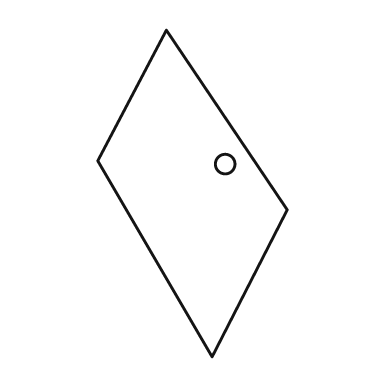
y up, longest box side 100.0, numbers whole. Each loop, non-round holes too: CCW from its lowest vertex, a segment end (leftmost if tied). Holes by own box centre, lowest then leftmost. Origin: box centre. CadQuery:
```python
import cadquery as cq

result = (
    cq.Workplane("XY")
    .moveTo(6.0, -50.0)
    .lineTo(29.0, -5.0)
    .lineTo(-8.0, 50.0)
    .lineTo(-29.0, 10.0)
    .close()
    .moveTo(10.0, 9.0)
    .circle(3.0)
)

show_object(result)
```